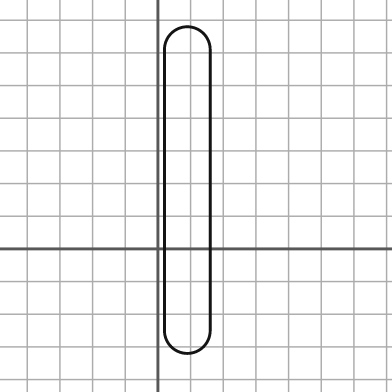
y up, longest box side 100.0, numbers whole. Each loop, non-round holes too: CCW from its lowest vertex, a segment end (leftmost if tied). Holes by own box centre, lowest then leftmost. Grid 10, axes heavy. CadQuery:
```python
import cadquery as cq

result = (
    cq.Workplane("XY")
    .moveTo(2.0, -25.0)
    .threePointArc((9.0, -32.0), (16.0, -25.0))
    .lineTo(16.0, 61.0)
    .threePointArc((9.0, 68.0), (2.0, 61.0))
    .close()
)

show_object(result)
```